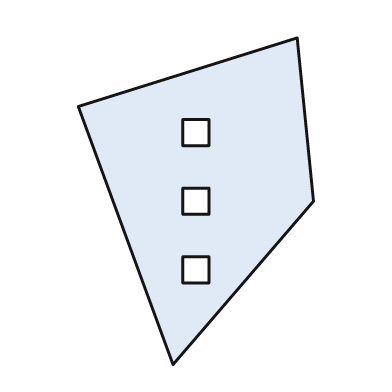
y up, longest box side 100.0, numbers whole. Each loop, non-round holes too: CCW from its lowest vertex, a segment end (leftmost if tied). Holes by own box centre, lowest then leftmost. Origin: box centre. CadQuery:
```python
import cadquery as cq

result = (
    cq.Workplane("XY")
    .moveTo(-7.0, -50.0)
    .lineTo(36.0, 0.0)
    .lineTo(31.0, 50.0)
    .lineTo(-36.0, 29.0)
    .close()
    .moveTo(-4.0, -25.0)
    .lineTo(4.0, -25.0)
    .lineTo(4.0, -17.0)
    .lineTo(-4.0, -17.0)
    .close()
    .moveTo(-4.0, -4.0)
    .lineTo(4.0, -4.0)
    .lineTo(4.0, 4.0)
    .lineTo(-4.0, 4.0)
    .close()
    .moveTo(-4.0, 17.0)
    .lineTo(4.0, 17.0)
    .lineTo(4.0, 25.0)
    .lineTo(-4.0, 25.0)
    .close()
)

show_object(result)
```